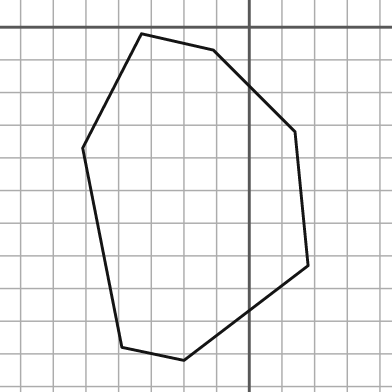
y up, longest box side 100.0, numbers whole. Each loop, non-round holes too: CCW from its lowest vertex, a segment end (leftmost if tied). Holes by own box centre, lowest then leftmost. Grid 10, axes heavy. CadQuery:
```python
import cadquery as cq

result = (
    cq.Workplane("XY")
    .moveTo(-20.0, -102.0)
    .lineTo(18.0, -73.0)
    .lineTo(14.0, -32.0)
    .lineTo(-11.0, -7.0)
    .lineTo(-33.0, -2.0)
    .lineTo(-51.0, -37.0)
    .lineTo(-39.0, -98.0)
    .close()
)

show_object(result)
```